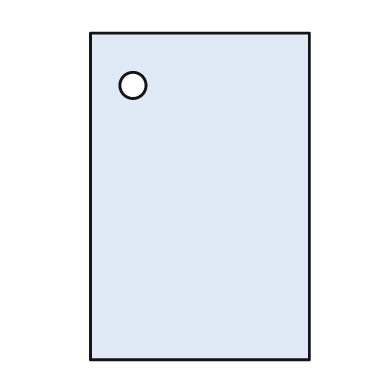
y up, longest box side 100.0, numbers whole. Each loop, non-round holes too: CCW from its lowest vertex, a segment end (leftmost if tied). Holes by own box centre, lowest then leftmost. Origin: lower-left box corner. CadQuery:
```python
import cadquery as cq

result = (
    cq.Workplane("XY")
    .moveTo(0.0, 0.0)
    .lineTo(67.0, 0.0)
    .lineTo(67.0, 100.0)
    .lineTo(0.0, 100.0)
    .close()
    .moveTo(13.0, 84.0)
    .circle(4.0)
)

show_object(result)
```